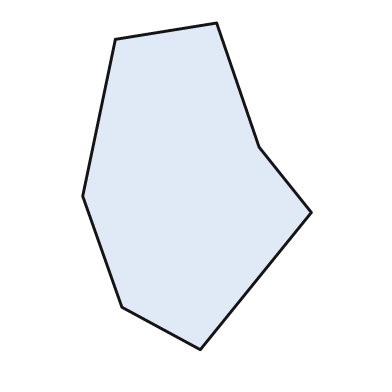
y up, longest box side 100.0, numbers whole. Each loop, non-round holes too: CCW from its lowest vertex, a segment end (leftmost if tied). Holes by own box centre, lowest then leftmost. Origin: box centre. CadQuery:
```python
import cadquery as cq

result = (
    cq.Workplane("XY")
    .moveTo(1.0, -50.0)
    .lineTo(35.0, -8.0)
    .lineTo(19.0, 12.0)
    .lineTo(6.0, 50.0)
    .lineTo(-25.0, 45.0)
    .lineTo(-35.0, -3.0)
    .lineTo(-23.0, -37.0)
    .close()
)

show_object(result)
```